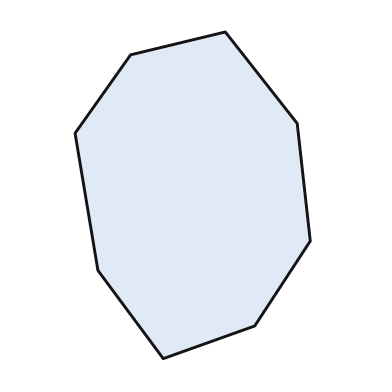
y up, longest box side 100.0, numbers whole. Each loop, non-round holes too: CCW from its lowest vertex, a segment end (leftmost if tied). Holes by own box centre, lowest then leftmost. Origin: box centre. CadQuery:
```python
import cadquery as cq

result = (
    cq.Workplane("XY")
    .moveTo(-9.0, -50.0)
    .lineTo(19.0, -40.0)
    .lineTo(36.0, -14.0)
    .lineTo(32.0, 22.0)
    .lineTo(10.0, 50.0)
    .lineTo(-19.0, 43.0)
    .lineTo(-36.0, 19.0)
    .lineTo(-29.0, -23.0)
    .close()
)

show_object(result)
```